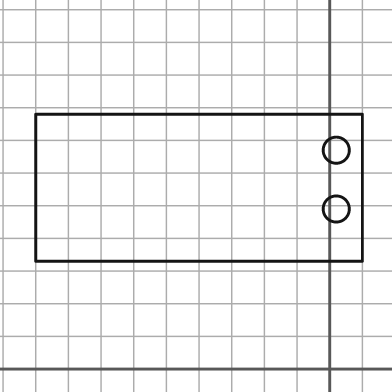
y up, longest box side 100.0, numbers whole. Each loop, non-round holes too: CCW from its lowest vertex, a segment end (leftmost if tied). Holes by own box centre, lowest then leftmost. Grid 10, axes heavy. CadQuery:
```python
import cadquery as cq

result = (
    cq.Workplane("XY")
    .moveTo(-90.0, 33.0)
    .lineTo(10.0, 33.0)
    .lineTo(10.0, 78.0)
    .lineTo(-90.0, 78.0)
    .close()
    .moveTo(2.0, 49.0)
    .circle(4.0)
    .moveTo(2.0, 67.0)
    .circle(4.0)
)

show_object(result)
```